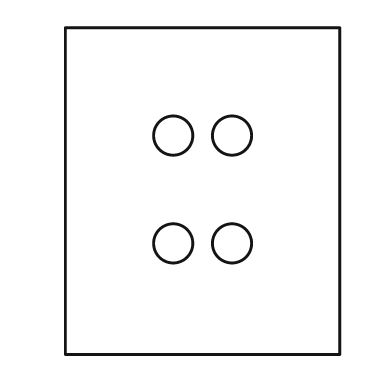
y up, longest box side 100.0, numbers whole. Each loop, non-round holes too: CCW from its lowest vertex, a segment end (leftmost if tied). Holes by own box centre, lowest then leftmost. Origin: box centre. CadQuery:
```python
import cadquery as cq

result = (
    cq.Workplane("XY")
    .moveTo(-42.0, -50.0)
    .lineTo(42.0, -50.0)
    .lineTo(42.0, 50.0)
    .lineTo(-42.0, 50.0)
    .close()
    .moveTo(-9.0, -16.0)
    .circle(6.0)
    .moveTo(9.0, -16.0)
    .circle(6.0)
    .moveTo(-9.0, 17.0)
    .circle(6.0)
    .moveTo(9.0, 17.0)
    .circle(6.0)
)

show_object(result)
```